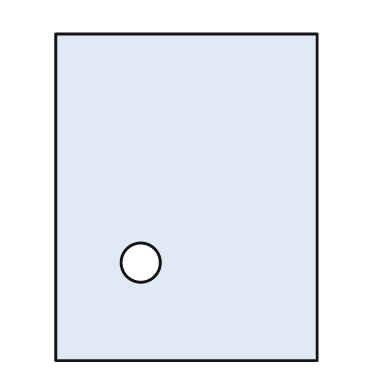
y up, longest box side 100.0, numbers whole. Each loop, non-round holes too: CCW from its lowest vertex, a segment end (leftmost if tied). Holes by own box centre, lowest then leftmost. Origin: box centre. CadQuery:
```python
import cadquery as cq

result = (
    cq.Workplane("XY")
    .moveTo(-40.0, -50.0)
    .lineTo(40.0, -50.0)
    .lineTo(40.0, 50.0)
    .lineTo(-40.0, 50.0)
    .close()
    .moveTo(-14.0, -20.0)
    .circle(6.0)
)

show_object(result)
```